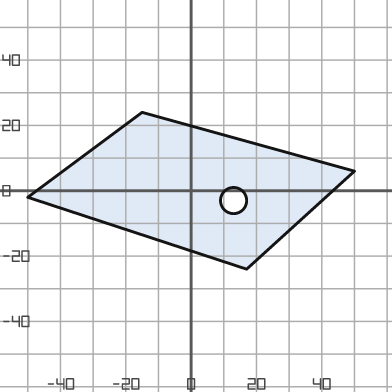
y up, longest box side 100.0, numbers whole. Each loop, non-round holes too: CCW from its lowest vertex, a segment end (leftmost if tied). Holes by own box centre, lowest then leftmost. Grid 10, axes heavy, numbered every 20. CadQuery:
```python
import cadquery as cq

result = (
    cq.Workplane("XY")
    .moveTo(17.0, -24.0)
    .lineTo(50.0, 6.0)
    .lineTo(-15.0, 24.0)
    .lineTo(-50.0, -2.0)
    .close()
    .moveTo(13.0, -3.0)
    .circle(4.0)
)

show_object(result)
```